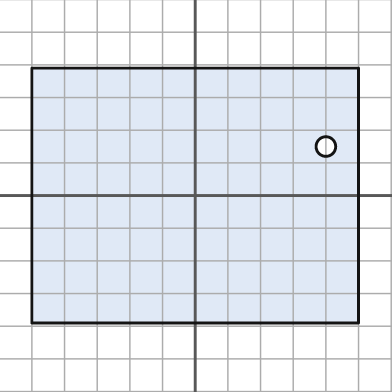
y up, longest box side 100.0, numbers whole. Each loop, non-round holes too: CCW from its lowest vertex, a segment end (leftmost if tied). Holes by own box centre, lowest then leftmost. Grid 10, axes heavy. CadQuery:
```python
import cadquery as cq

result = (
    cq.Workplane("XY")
    .moveTo(-50.0, -39.0)
    .lineTo(50.0, -39.0)
    .lineTo(50.0, 39.0)
    .lineTo(-50.0, 39.0)
    .close()
    .moveTo(40.0, 15.0)
    .circle(3.0)
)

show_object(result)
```